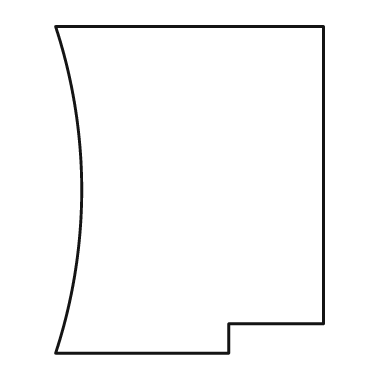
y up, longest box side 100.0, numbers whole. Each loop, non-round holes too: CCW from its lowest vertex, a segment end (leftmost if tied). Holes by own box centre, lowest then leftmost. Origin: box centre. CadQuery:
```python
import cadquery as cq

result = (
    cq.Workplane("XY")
    .moveTo(-41.0, -50.0)
    .lineTo(12.0, -50.0)
    .lineTo(12.0, -41.0)
    .lineTo(41.0, -41.0)
    .lineTo(41.0, 50.0)
    .lineTo(-41.0, 50.0)
    .threePointArc((-33.0, 0.0), (-41.0, -50.0))
    .close()
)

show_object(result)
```